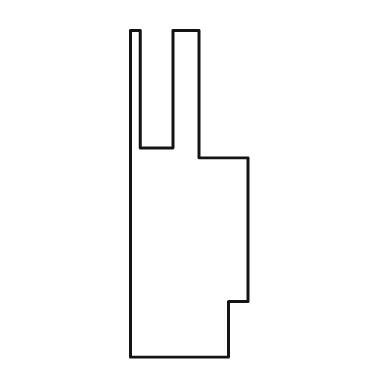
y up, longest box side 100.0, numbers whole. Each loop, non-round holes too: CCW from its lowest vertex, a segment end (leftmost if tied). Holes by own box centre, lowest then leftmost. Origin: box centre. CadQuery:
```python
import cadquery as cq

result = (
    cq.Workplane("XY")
    .moveTo(-18.0, -50.0)
    .lineTo(12.0, -50.0)
    .lineTo(12.0, -33.0)
    .lineTo(18.0, -33.0)
    .lineTo(18.0, 11.0)
    .lineTo(3.0, 11.0)
    .lineTo(3.0, 50.0)
    .lineTo(-5.0, 50.0)
    .lineTo(-5.0, 14.0)
    .lineTo(-15.0, 14.0)
    .lineTo(-15.0, 50.0)
    .lineTo(-18.0, 50.0)
    .close()
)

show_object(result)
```